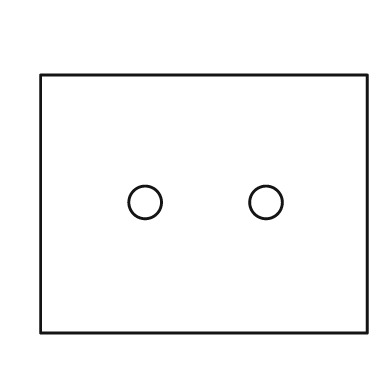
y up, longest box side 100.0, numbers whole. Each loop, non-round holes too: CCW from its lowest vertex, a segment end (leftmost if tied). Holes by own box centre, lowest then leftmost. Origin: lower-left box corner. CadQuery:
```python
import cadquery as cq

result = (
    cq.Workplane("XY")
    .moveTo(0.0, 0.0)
    .lineTo(100.0, 0.0)
    .lineTo(100.0, 79.0)
    .lineTo(0.0, 79.0)
    .close()
    .moveTo(32.0, 40.0)
    .circle(5.0)
    .moveTo(69.0, 40.0)
    .circle(5.0)
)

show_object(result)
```